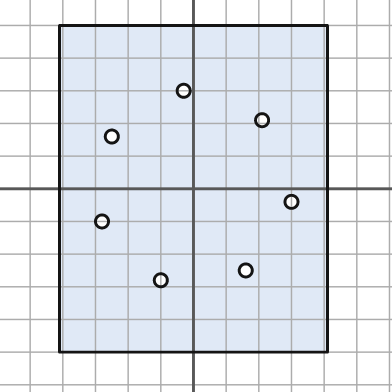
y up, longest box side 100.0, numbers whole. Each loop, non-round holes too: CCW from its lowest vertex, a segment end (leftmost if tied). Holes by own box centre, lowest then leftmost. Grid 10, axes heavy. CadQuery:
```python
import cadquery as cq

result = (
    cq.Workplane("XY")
    .moveTo(-41.0, -50.0)
    .lineTo(41.0, -50.0)
    .lineTo(41.0, 50.0)
    .lineTo(-41.0, 50.0)
    .close()
    .moveTo(-10.0, -28.0)
    .circle(2.0)
    .moveTo(16.0, -25.0)
    .circle(2.0)
    .moveTo(-28.0, -10.0)
    .circle(2.0)
    .moveTo(30.0, -4.0)
    .circle(2.0)
    .moveTo(-25.0, 16.0)
    .circle(2.0)
    .moveTo(21.0, 21.0)
    .circle(2.0)
    .moveTo(-3.0, 30.0)
    .circle(2.0)
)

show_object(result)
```